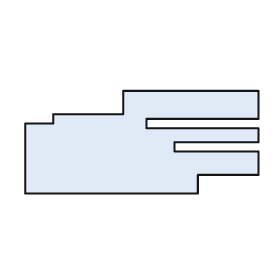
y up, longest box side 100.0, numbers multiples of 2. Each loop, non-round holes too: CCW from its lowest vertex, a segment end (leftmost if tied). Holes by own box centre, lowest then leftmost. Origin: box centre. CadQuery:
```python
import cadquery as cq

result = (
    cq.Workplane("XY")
    .moveTo(-50.0, -22.0)
    .lineTo(24.0, -22.0)
    .lineTo(24.0, -14.0)
    .lineTo(50.0, -14.0)
    .lineTo(50.0, -4.0)
    .lineTo(14.0, -4.0)
    .lineTo(14.0, 0.0)
    .lineTo(50.0, 0.0)
    .lineTo(50.0, 6.0)
    .lineTo(2.0, 6.0)
    .lineTo(2.0, 10.0)
    .lineTo(50.0, 10.0)
    .lineTo(50.0, 22.0)
    .lineTo(-8.0, 22.0)
    .lineTo(-8.0, 12.0)
    .lineTo(-38.0, 12.0)
    .lineTo(-38.0, 8.0)
    .lineTo(-50.0, 8.0)
    .close()
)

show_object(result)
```